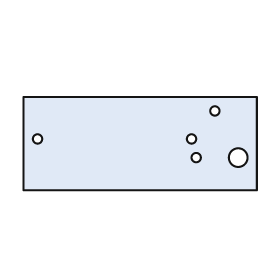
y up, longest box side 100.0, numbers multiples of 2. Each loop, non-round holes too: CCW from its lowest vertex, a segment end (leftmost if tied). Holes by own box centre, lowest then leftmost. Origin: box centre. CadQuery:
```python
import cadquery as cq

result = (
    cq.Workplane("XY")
    .moveTo(-50.0, -20.0)
    .lineTo(50.0, -20.0)
    .lineTo(50.0, 20.0)
    .lineTo(-50.0, 20.0)
    .close()
    .moveTo(24.0, -6.0)
    .circle(2.0)
    .moveTo(42.0, -6.0)
    .circle(4.0)
    .moveTo(-44.0, 2.0)
    .circle(2.0)
    .moveTo(22.0, 2.0)
    .circle(2.0)
    .moveTo(32.0, 14.0)
    .circle(2.0)
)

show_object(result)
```